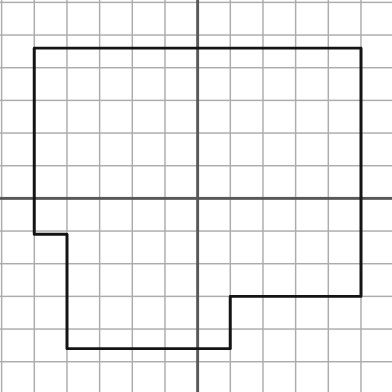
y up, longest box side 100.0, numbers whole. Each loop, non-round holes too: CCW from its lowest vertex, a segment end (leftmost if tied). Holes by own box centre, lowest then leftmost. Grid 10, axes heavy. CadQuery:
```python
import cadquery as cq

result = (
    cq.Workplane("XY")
    .moveTo(-40.0, -46.0)
    .lineTo(10.0, -46.0)
    .lineTo(10.0, -30.0)
    .lineTo(50.0, -30.0)
    .lineTo(50.0, 46.0)
    .lineTo(-50.0, 46.0)
    .lineTo(-50.0, -11.0)
    .lineTo(-40.0, -11.0)
    .close()
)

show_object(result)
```